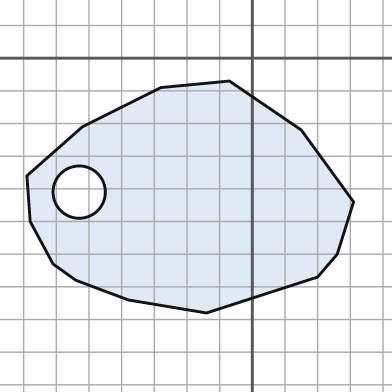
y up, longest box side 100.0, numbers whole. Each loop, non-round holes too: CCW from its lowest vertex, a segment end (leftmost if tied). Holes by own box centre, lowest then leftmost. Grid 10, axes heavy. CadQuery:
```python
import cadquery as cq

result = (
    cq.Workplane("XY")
    .moveTo(-14.0, -78.0)
    .lineTo(20.0, -67.0)
    .lineTo(26.0, -60.0)
    .lineTo(31.0, -44.0)
    .lineTo(15.0, -22.0)
    .lineTo(-7.0, -7.0)
    .lineTo(-28.0, -9.0)
    .lineTo(-52.0, -21.0)
    .lineTo(-69.0, -36.0)
    .lineTo(-68.0, -50.0)
    .lineTo(-61.0, -63.0)
    .lineTo(-54.0, -68.0)
    .lineTo(-38.0, -74.0)
    .close()
    .moveTo(-53.0, -41.0)
    .circle(8.0)
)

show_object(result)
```